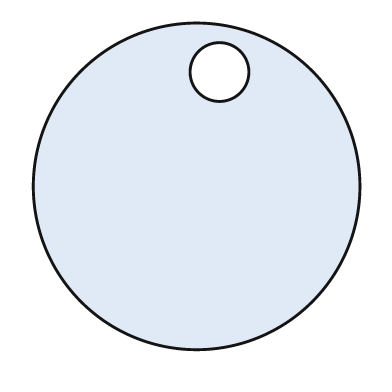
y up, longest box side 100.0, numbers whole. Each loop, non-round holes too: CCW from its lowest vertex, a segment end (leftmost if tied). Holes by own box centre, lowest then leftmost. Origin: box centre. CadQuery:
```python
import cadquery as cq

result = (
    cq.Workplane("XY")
    .moveTo(0.0, 0.0)
    .circle(50.0)
    .moveTo(7.0, 35.0)
    .circle(9.0)
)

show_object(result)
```